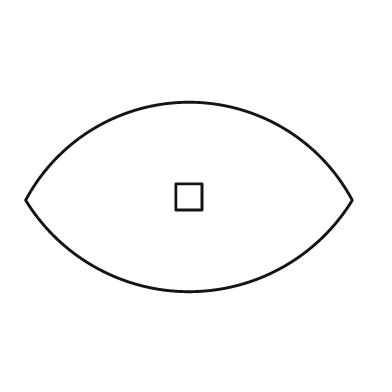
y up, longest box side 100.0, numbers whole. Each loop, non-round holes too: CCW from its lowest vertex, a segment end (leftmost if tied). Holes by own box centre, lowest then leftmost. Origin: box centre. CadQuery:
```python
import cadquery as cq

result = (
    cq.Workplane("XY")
    .moveTo(-50.0, -1.0)
    .threePointArc((0.0, -29.0), (50.0, -1.0))
    .threePointArc((0.0, 29.0), (-50.0, -1.0))
    .close()
    .moveTo(-4.0, -4.0)
    .lineTo(4.0, -4.0)
    .lineTo(4.0, 4.0)
    .lineTo(-4.0, 4.0)
    .close()
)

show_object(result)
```